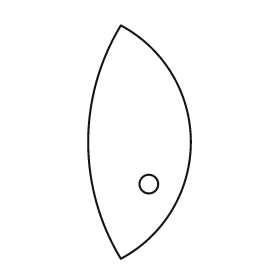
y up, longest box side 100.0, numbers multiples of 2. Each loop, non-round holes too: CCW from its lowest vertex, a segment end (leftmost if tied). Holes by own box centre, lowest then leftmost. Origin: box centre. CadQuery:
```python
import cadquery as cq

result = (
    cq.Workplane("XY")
    .moveTo(-8.0, -50.0)
    .threePointArc((22.0, 0.0), (-8.0, 50.0))
    .threePointArc((-22.0, 0.0), (-8.0, -50.0))
    .close()
    .moveTo(4.0, -18.0)
    .circle(4.0)
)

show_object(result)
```